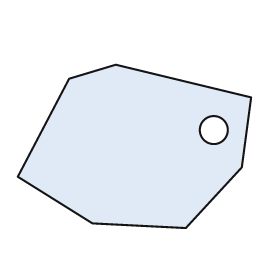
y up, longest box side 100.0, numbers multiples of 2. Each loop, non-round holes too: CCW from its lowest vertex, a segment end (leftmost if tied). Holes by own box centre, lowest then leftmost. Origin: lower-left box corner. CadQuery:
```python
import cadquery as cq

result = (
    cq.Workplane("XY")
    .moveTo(72.0, 0.0)
    .lineTo(96.0, 26.0)
    .lineTo(100.0, 56.0)
    .lineTo(42.0, 70.0)
    .lineTo(22.0, 64.0)
    .lineTo(0.0, 22.0)
    .lineTo(32.0, 2.0)
    .close()
    .moveTo(84.0, 42.0)
    .circle(6.0)
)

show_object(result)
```